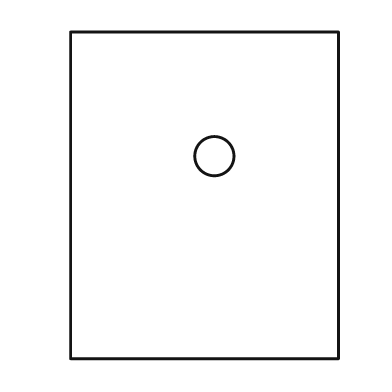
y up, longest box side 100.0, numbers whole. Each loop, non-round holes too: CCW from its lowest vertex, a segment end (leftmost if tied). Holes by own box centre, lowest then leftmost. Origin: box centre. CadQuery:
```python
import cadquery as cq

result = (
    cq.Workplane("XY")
    .moveTo(-41.0, -50.0)
    .lineTo(41.0, -50.0)
    .lineTo(41.0, 50.0)
    .lineTo(-41.0, 50.0)
    .close()
    .moveTo(3.0, 12.0)
    .circle(6.0)
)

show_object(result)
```